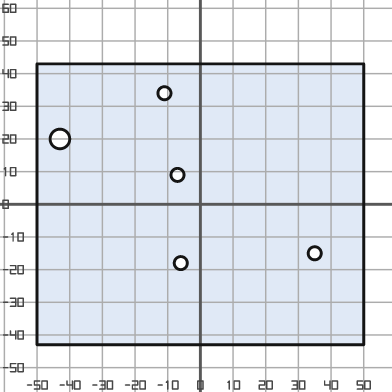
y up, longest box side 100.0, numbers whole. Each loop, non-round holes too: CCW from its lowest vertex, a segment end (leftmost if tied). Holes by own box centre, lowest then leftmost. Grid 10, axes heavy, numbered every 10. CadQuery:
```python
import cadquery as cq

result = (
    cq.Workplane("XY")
    .moveTo(-50.0, -43.0)
    .lineTo(50.0, -43.0)
    .lineTo(50.0, 43.0)
    .lineTo(-50.0, 43.0)
    .close()
    .moveTo(-6.0, -18.0)
    .circle(2.0)
    .moveTo(35.0, -15.0)
    .circle(2.0)
    .moveTo(-7.0, 9.0)
    .circle(2.0)
    .moveTo(-43.0, 20.0)
    .circle(3.0)
    .moveTo(-11.0, 34.0)
    .circle(2.0)
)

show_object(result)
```